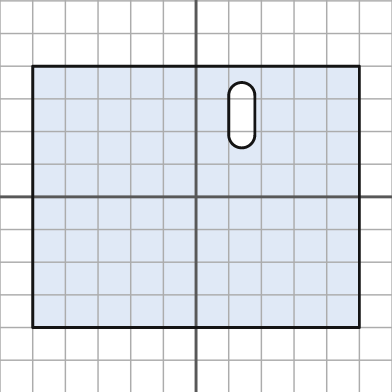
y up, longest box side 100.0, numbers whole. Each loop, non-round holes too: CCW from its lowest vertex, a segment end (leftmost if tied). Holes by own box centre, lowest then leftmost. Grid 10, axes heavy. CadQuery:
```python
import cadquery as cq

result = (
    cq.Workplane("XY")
    .moveTo(-50.0, -40.0)
    .lineTo(50.0, -40.0)
    .lineTo(50.0, 40.0)
    .lineTo(-50.0, 40.0)
    .close()
    .moveTo(10.0, 19.0)
    .threePointArc((14.0, 15.0), (18.0, 19.0))
    .lineTo(18.0, 31.0)
    .threePointArc((14.0, 35.0), (10.0, 31.0))
    .close()
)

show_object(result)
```